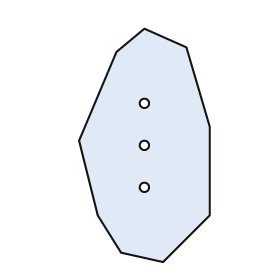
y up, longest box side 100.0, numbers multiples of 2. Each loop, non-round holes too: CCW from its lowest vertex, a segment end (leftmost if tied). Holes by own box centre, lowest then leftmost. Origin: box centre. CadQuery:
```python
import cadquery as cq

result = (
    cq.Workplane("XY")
    .moveTo(8.0, -50.0)
    .lineTo(28.0, -30.0)
    .lineTo(28.0, 8.0)
    .lineTo(18.0, 42.0)
    .lineTo(0.0, 50.0)
    .lineTo(-12.0, 40.0)
    .lineTo(-28.0, 2.0)
    .lineTo(-20.0, -30.0)
    .lineTo(-10.0, -46.0)
    .close()
    .moveTo(0.0, -18.0)
    .circle(2.0)
    .moveTo(0.0, 0.0)
    .circle(2.0)
    .moveTo(0.0, 18.0)
    .circle(2.0)
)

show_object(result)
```